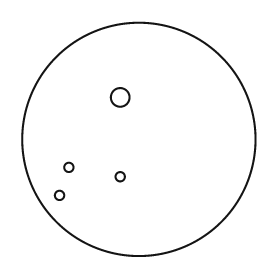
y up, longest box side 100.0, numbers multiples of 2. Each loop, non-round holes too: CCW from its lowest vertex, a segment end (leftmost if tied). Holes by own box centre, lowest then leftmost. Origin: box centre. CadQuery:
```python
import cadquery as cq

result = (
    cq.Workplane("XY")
    .moveTo(0.0, 0.0)
    .circle(50.0)
    .moveTo(-34.0, -24.0)
    .circle(2.0)
    .moveTo(-8.0, -16.0)
    .circle(2.0)
    .moveTo(-30.0, -12.0)
    .circle(2.0)
    .moveTo(-8.0, 18.0)
    .circle(4.0)
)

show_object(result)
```